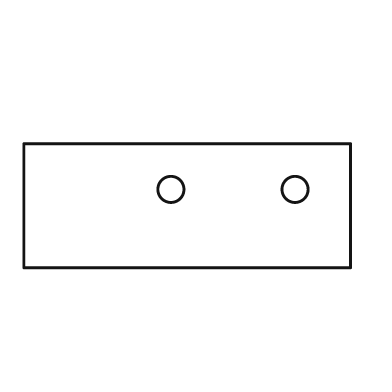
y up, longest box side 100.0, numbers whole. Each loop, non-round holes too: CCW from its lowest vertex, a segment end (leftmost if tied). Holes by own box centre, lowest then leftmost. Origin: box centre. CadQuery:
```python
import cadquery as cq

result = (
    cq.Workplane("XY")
    .moveTo(-50.0, -19.0)
    .lineTo(50.0, -19.0)
    .lineTo(50.0, 19.0)
    .lineTo(-50.0, 19.0)
    .close()
    .moveTo(-5.0, 5.0)
    .circle(4.0)
    .moveTo(33.0, 5.0)
    .circle(4.0)
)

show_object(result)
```